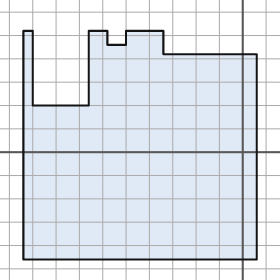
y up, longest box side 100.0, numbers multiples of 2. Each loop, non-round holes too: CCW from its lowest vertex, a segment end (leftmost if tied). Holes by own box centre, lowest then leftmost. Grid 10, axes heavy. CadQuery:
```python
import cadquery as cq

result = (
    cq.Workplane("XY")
    .moveTo(-94.0, -46.0)
    .lineTo(6.0, -46.0)
    .lineTo(6.0, 42.0)
    .lineTo(-34.0, 42.0)
    .lineTo(-34.0, 52.0)
    .lineTo(-50.0, 52.0)
    .lineTo(-50.0, 46.0)
    .lineTo(-58.0, 46.0)
    .lineTo(-58.0, 52.0)
    .lineTo(-66.0, 52.0)
    .lineTo(-66.0, 20.0)
    .lineTo(-90.0, 20.0)
    .lineTo(-90.0, 52.0)
    .lineTo(-94.0, 52.0)
    .close()
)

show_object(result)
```